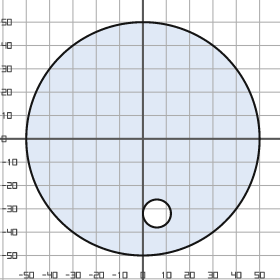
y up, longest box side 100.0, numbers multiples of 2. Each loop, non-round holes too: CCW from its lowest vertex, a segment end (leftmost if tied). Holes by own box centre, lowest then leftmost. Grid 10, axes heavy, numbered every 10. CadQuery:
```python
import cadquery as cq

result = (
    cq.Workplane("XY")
    .moveTo(0.0, 0.0)
    .circle(50.0)
    .moveTo(6.0, -32.0)
    .circle(6.0)
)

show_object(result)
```